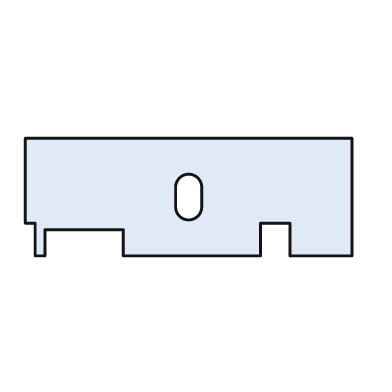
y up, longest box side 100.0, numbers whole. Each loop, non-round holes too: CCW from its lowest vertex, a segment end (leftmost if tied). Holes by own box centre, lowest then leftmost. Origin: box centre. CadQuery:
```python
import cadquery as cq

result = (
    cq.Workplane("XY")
    .moveTo(-47.0, -18.0)
    .lineTo(-44.0, -18.0)
    .lineTo(-44.0, -10.0)
    .lineTo(-20.0, -10.0)
    .lineTo(-20.0, -18.0)
    .lineTo(22.0, -18.0)
    .lineTo(22.0, -8.0)
    .lineTo(31.0, -8.0)
    .lineTo(31.0, -18.0)
    .lineTo(50.0, -18.0)
    .lineTo(50.0, 18.0)
    .lineTo(-50.0, 18.0)
    .lineTo(-50.0, -8.0)
    .lineTo(-47.0, -8.0)
    .close()
    .moveTo(-4.0, -3.0)
    .threePointArc((0.0, -7.0), (4.0, -3.0))
    .lineTo(4.0, 3.0)
    .threePointArc((0.0, 7.0), (-4.0, 3.0))
    .close()
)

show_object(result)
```